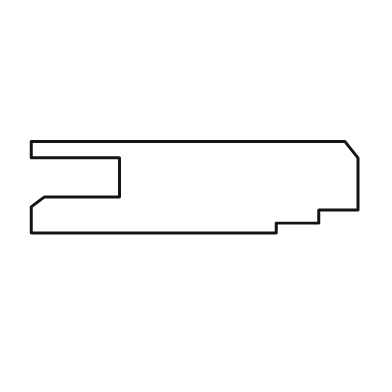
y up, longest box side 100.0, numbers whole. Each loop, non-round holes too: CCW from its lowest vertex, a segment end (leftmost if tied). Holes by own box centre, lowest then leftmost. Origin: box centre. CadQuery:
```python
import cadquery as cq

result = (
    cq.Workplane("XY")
    .moveTo(-50.0, -14.0)
    .lineTo(25.0, -14.0)
    .lineTo(25.0, -11.0)
    .lineTo(38.0, -11.0)
    .lineTo(38.0, -7.0)
    .lineTo(50.0, -7.0)
    .lineTo(50.0, 9.0)
    .lineTo(46.0, 14.0)
    .lineTo(-50.0, 14.0)
    .lineTo(-50.0, 9.0)
    .lineTo(-23.0, 9.0)
    .lineTo(-23.0, -3.0)
    .lineTo(-46.0, -3.0)
    .lineTo(-50.0, -6.0)
    .close()
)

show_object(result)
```